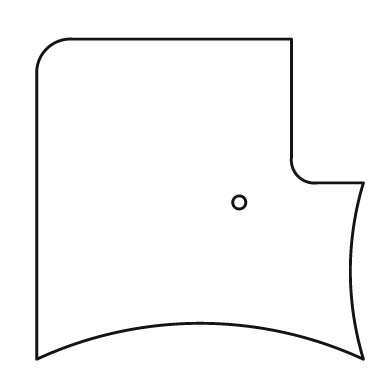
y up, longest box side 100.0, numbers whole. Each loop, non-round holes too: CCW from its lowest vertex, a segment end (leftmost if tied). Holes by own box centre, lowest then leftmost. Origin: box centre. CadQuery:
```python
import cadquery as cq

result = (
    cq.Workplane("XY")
    .moveTo(-50.0, -49.0)
    .threePointArc((0.0, -38.0), (50.0, -49.0))
    .threePointArc((46.0, -22.0), (50.0, 5.0))
    .lineTo(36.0, 5.0)
    .threePointArc((30.0, 7.0), (28.0, 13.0))
    .lineTo(28.0, 49.0)
    .lineTo(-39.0, 49.0)
    .threePointArc((-47.0, 46.0), (-50.0, 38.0))
    .close()
    .moveTo(12.0, -1.0)
    .circle(2.0)
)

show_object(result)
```